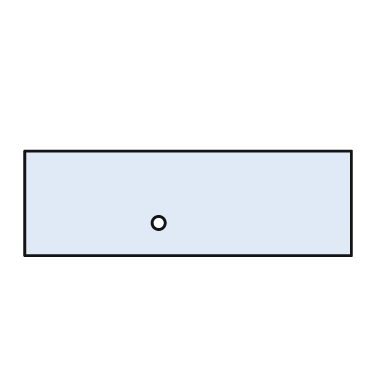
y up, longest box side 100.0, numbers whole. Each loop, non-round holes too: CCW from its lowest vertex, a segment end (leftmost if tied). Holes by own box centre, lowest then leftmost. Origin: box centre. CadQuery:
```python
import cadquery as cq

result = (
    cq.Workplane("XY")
    .moveTo(-50.0, -16.0)
    .lineTo(50.0, -16.0)
    .lineTo(50.0, 16.0)
    .lineTo(-50.0, 16.0)
    .close()
    .moveTo(-9.0, -6.0)
    .circle(2.0)
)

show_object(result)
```